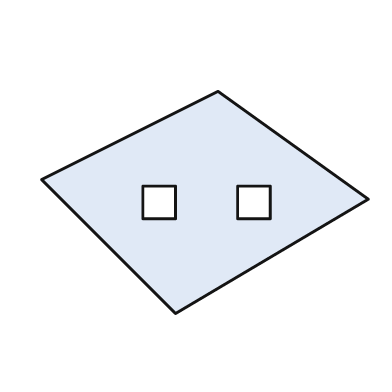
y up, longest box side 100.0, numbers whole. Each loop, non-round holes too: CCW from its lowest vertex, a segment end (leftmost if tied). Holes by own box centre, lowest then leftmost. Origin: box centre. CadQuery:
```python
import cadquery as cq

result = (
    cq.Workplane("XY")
    .moveTo(-9.0, -34.0)
    .lineTo(50.0, 1.0)
    .lineTo(4.0, 34.0)
    .lineTo(-50.0, 7.0)
    .close()
    .moveTo(-19.0, -5.0)
    .lineTo(-9.0, -5.0)
    .lineTo(-9.0, 5.0)
    .lineTo(-19.0, 5.0)
    .close()
    .moveTo(10.0, -5.0)
    .lineTo(20.0, -5.0)
    .lineTo(20.0, 5.0)
    .lineTo(10.0, 5.0)
    .close()
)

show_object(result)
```